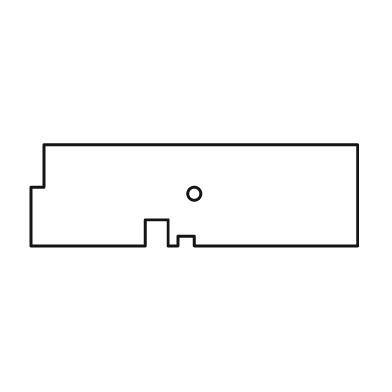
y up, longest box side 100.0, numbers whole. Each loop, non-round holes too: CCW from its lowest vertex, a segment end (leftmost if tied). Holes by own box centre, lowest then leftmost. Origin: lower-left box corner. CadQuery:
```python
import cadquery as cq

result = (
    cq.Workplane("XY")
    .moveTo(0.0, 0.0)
    .lineTo(35.0, 0.0)
    .lineTo(35.0, 8.0)
    .lineTo(42.0, 8.0)
    .lineTo(42.0, 0.0)
    .lineTo(45.0, 0.0)
    .lineTo(45.0, 3.0)
    .lineTo(50.0, 3.0)
    .lineTo(50.0, 0.0)
    .lineTo(100.0, 0.0)
    .lineTo(100.0, 31.0)
    .lineTo(4.0, 31.0)
    .lineTo(4.0, 18.0)
    .lineTo(0.0, 18.0)
    .close()
    .moveTo(50.0, 16.0)
    .circle(2.0)
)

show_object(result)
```